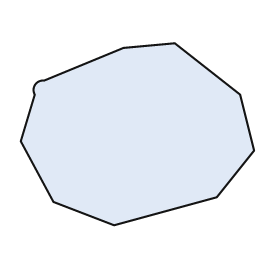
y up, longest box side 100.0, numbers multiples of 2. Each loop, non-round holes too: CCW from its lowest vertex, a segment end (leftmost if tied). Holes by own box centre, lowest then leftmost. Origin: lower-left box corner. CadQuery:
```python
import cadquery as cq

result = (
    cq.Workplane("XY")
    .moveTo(40.0, 0.0)
    .lineTo(84.0, 12.0)
    .lineTo(100.0, 32.0)
    .lineTo(94.0, 56.0)
    .lineTo(66.0, 78.0)
    .lineTo(44.0, 76.0)
    .lineTo(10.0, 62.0)
    .threePointArc((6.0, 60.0), (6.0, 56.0))
    .lineTo(0.0, 36.0)
    .lineTo(14.0, 10.0)
    .close()
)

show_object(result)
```